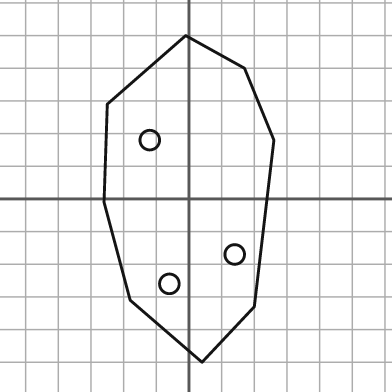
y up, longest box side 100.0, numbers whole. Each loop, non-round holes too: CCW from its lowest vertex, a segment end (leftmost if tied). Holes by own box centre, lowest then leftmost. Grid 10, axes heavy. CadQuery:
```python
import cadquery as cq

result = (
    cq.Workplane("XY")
    .moveTo(4.0, -50.0)
    .lineTo(20.0, -33.0)
    .lineTo(26.0, 18.0)
    .lineTo(17.0, 40.0)
    .lineTo(-1.0, 50.0)
    .lineTo(-25.0, 29.0)
    .lineTo(-26.0, -1.0)
    .lineTo(-18.0, -31.0)
    .close()
    .moveTo(-6.0, -26.0)
    .circle(3.0)
    .moveTo(14.0, -17.0)
    .circle(3.0)
    .moveTo(-12.0, 18.0)
    .circle(3.0)
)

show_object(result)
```